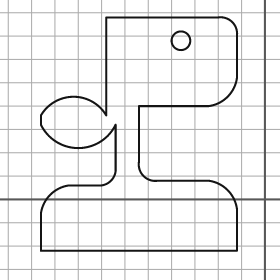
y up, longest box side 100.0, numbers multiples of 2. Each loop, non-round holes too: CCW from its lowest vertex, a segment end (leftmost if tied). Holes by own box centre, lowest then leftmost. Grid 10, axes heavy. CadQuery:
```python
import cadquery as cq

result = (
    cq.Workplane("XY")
    .moveTo(-96.0, -22.0)
    .lineTo(-12.0, -22.0)
    .lineTo(-12.0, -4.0)
    .threePointArc((-16.0, 4.0), (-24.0, 8.0))
    .lineTo(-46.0, 8.0)
    .threePointArc((-52.0, 10.0), (-54.0, 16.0))
    .lineTo(-54.0, 40.0)
    .lineTo(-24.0, 40.0)
    .threePointArc((-16.0, 44.0), (-12.0, 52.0))
    .lineTo(-12.0, 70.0)
    .threePointArc((-14.0, 76.0), (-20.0, 78.0))
    .lineTo(-68.0, 78.0)
    .lineTo(-68.0, 36.0)
    .threePointArc((-82.0, 44.0), (-96.0, 36.0))
    .lineTo(-96.0, 32.0)
    .threePointArc((-80.0, 22.0), (-64.0, 32.0))
    .lineTo(-64.0, 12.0)
    .threePointArc((-66.0, 8.0), (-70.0, 6.0))
    .lineTo(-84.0, 6.0)
    .threePointArc((-92.0, 2.0), (-96.0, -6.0))
    .close()
    .moveTo(-36.0, 68.0)
    .circle(4.0)
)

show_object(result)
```